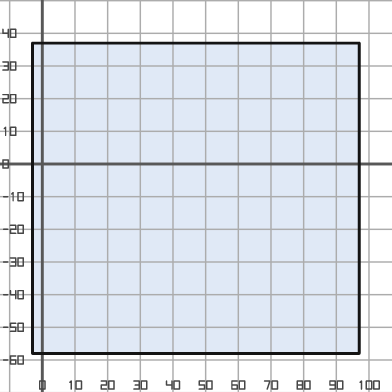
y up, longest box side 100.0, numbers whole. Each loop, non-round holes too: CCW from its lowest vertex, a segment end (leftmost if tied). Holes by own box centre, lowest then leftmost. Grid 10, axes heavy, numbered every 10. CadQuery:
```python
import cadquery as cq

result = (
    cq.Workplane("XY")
    .moveTo(-3.0, -58.0)
    .lineTo(97.0, -58.0)
    .lineTo(97.0, 37.0)
    .lineTo(-3.0, 37.0)
    .close()
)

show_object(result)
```